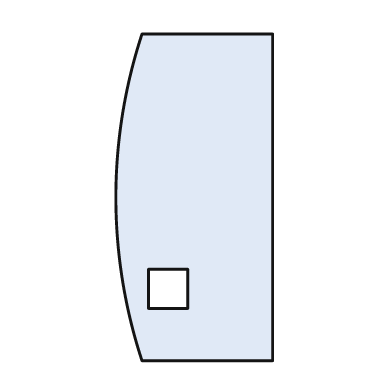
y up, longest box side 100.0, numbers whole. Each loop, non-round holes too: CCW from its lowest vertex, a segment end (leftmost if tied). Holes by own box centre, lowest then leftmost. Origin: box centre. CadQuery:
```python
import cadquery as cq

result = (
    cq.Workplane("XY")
    .moveTo(-16.0, -50.0)
    .lineTo(24.0, -50.0)
    .lineTo(24.0, 50.0)
    .lineTo(-16.0, 50.0)
    .threePointArc((-24.0, 0.0), (-16.0, -50.0))
    .close()
    .moveTo(-14.0, -34.0)
    .lineTo(-2.0, -34.0)
    .lineTo(-2.0, -22.0)
    .lineTo(-14.0, -22.0)
    .close()
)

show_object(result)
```